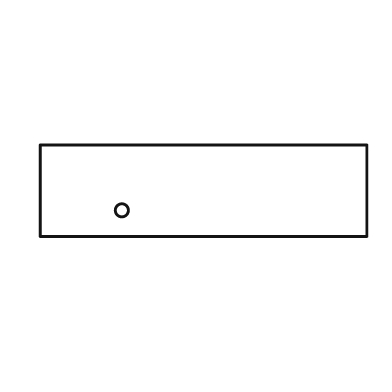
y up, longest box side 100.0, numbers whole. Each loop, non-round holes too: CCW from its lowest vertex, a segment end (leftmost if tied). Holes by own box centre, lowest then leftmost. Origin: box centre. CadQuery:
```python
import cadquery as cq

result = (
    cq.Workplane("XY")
    .moveTo(-50.0, -14.0)
    .lineTo(50.0, -14.0)
    .lineTo(50.0, 14.0)
    .lineTo(-50.0, 14.0)
    .close()
    .moveTo(-25.0, -6.0)
    .circle(2.0)
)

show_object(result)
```